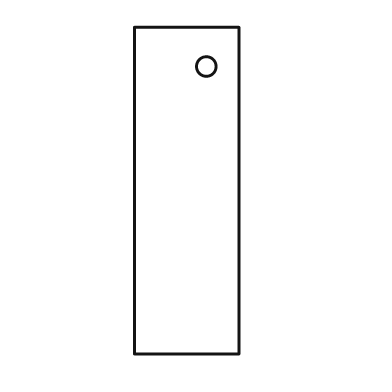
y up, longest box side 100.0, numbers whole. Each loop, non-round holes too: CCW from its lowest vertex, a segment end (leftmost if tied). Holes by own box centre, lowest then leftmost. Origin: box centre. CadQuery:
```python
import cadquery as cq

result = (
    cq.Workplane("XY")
    .moveTo(-16.0, -50.0)
    .lineTo(16.0, -50.0)
    .lineTo(16.0, 50.0)
    .lineTo(-16.0, 50.0)
    .close()
    .moveTo(6.0, 38.0)
    .circle(3.0)
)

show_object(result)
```